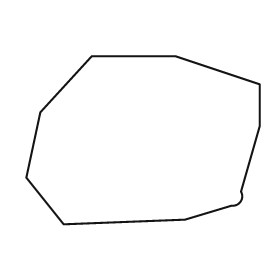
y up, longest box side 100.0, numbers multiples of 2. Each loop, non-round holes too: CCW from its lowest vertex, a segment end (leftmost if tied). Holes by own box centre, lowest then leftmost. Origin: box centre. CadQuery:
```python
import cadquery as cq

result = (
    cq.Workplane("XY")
    .moveTo(-34.0, -36.0)
    .lineTo(18.0, -34.0)
    .lineTo(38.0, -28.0)
    .threePointArc((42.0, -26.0), (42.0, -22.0))
    .lineTo(50.0, 6.0)
    .lineTo(50.0, 24.0)
    .lineTo(14.0, 36.0)
    .lineTo(-22.0, 36.0)
    .lineTo(-44.0, 12.0)
    .lineTo(-50.0, -16.0)
    .close()
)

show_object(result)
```